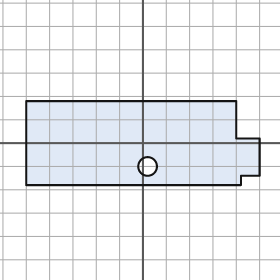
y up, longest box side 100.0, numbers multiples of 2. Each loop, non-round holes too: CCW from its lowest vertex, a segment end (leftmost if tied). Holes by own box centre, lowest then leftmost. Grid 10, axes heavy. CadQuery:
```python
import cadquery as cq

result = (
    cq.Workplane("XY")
    .moveTo(-50.0, -18.0)
    .lineTo(42.0, -18.0)
    .lineTo(42.0, -14.0)
    .lineTo(50.0, -14.0)
    .lineTo(50.0, 2.0)
    .lineTo(40.0, 2.0)
    .lineTo(40.0, 18.0)
    .lineTo(-50.0, 18.0)
    .close()
    .moveTo(2.0, -10.0)
    .circle(4.0)
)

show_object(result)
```